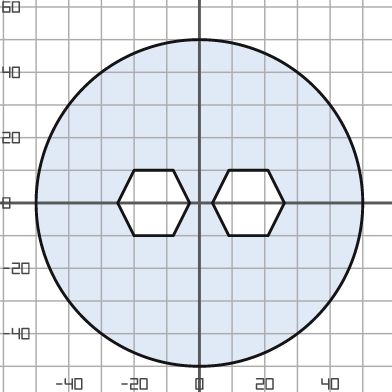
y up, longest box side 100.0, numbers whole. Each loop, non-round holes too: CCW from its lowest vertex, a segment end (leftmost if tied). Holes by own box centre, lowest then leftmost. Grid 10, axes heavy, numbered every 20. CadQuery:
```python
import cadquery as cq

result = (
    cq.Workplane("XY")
    .moveTo(0.0, 0.0)
    .circle(50.0)
    .moveTo(-20.0, -10.0)
    .lineTo(-8.0, -10.0)
    .lineTo(-3.0, 0.0)
    .lineTo(-8.0, 10.0)
    .lineTo(-20.0, 10.0)
    .lineTo(-25.0, 0.0)
    .close()
    .moveTo(9.0, -10.0)
    .lineTo(21.0, -10.0)
    .lineTo(26.0, 0.0)
    .lineTo(21.0, 10.0)
    .lineTo(9.0, 10.0)
    .lineTo(4.0, 0.0)
    .close()
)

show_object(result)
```